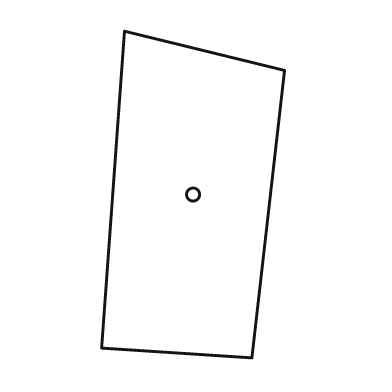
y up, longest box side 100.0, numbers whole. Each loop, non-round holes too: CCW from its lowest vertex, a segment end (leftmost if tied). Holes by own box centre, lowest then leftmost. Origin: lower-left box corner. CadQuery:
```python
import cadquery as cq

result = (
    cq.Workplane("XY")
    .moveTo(46.0, 0.0)
    .lineTo(56.0, 88.0)
    .lineTo(7.0, 100.0)
    .lineTo(0.0, 3.0)
    .close()
    .moveTo(28.0, 50.0)
    .circle(2.0)
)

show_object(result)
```